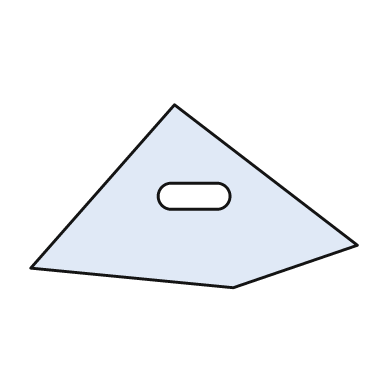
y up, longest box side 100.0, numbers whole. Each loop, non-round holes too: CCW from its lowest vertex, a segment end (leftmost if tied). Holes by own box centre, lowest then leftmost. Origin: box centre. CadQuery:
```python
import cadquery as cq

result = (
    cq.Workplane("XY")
    .moveTo(12.0, -28.0)
    .lineTo(50.0, -15.0)
    .lineTo(-6.0, 28.0)
    .lineTo(-50.0, -22.0)
    .close()
    .moveTo(-7.0, -4.0)
    .lineTo(7.0, -4.0)
    .threePointArc((11.0, 0.0), (7.0, 4.0))
    .lineTo(-7.0, 4.0)
    .threePointArc((-11.0, 0.0), (-7.0, -4.0))
    .close()
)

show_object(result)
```